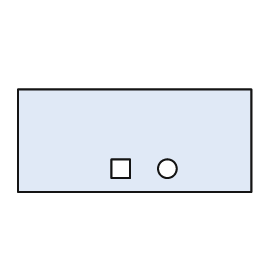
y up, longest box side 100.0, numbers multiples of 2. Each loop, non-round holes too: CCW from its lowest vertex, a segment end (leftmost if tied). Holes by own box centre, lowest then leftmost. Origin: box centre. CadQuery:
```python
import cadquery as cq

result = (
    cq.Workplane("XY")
    .moveTo(-50.0, -22.0)
    .lineTo(50.0, -22.0)
    .lineTo(50.0, 22.0)
    .lineTo(-50.0, 22.0)
    .close()
    .moveTo(-10.0, -16.0)
    .lineTo(-2.0, -16.0)
    .lineTo(-2.0, -8.0)
    .lineTo(-10.0, -8.0)
    .close()
    .moveTo(14.0, -12.0)
    .circle(4.0)
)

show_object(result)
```